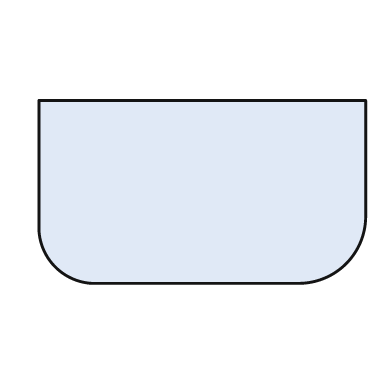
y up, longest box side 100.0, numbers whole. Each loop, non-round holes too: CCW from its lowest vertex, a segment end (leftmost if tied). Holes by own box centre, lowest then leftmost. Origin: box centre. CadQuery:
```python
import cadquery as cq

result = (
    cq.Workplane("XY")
    .moveTo(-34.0, -28.0)
    .lineTo(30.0, -28.0)
    .threePointArc((44.0, -22.0), (50.0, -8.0))
    .lineTo(50.0, 28.0)
    .lineTo(-50.0, 28.0)
    .lineTo(-50.0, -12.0)
    .threePointArc((-45.0, -23.0), (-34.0, -28.0))
    .close()
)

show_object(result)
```